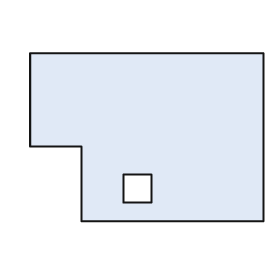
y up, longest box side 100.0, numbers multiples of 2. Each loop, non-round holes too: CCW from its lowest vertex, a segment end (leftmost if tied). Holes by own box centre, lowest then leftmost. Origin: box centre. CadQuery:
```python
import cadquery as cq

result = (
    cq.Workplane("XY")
    .moveTo(-28.0, -36.0)
    .lineTo(50.0, -36.0)
    .lineTo(50.0, 36.0)
    .lineTo(-50.0, 36.0)
    .lineTo(-50.0, -4.0)
    .lineTo(-28.0, -4.0)
    .close()
    .moveTo(-10.0, -28.0)
    .lineTo(2.0, -28.0)
    .lineTo(2.0, -16.0)
    .lineTo(-10.0, -16.0)
    .close()
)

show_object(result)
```